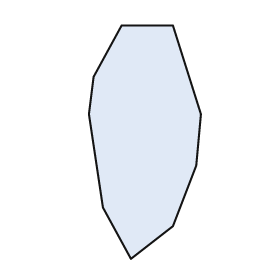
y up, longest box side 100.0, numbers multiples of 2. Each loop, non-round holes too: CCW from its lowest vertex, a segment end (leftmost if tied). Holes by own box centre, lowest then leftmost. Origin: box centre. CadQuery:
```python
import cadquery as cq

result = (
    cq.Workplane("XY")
    .moveTo(-6.0, -50.0)
    .lineTo(12.0, -36.0)
    .lineTo(22.0, -10.0)
    .lineTo(24.0, 12.0)
    .lineTo(12.0, 50.0)
    .lineTo(-10.0, 50.0)
    .lineTo(-22.0, 28.0)
    .lineTo(-24.0, 12.0)
    .lineTo(-18.0, -28.0)
    .close()
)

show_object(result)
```